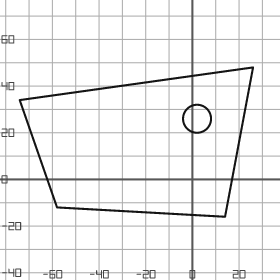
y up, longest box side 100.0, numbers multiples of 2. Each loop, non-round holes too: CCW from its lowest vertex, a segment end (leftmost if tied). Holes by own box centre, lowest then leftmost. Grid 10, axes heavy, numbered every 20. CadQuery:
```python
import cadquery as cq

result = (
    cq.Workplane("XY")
    .moveTo(14.0, -16.0)
    .lineTo(26.0, 48.0)
    .lineTo(-74.0, 34.0)
    .lineTo(-58.0, -12.0)
    .close()
    .moveTo(2.0, 26.0)
    .circle(6.0)
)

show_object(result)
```